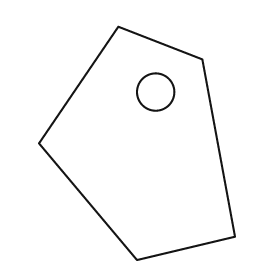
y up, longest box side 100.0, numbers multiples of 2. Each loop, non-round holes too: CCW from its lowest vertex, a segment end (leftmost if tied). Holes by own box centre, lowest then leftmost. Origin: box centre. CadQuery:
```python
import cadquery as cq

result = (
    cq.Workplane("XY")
    .moveTo(0.0, -50.0)
    .lineTo(42.0, -40.0)
    .lineTo(28.0, 36.0)
    .lineTo(-8.0, 50.0)
    .lineTo(-42.0, 0.0)
    .close()
    .moveTo(8.0, 22.0)
    .circle(8.0)
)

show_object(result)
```